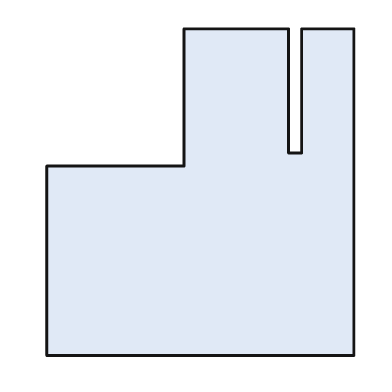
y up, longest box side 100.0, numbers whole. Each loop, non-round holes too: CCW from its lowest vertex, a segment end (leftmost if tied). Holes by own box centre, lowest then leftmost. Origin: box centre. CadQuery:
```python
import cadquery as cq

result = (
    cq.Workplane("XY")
    .moveTo(-47.0, -50.0)
    .lineTo(47.0, -50.0)
    .lineTo(47.0, 50.0)
    .lineTo(31.0, 50.0)
    .lineTo(31.0, 12.0)
    .lineTo(27.0, 12.0)
    .lineTo(27.0, 50.0)
    .lineTo(-5.0, 50.0)
    .lineTo(-5.0, 8.0)
    .lineTo(-47.0, 8.0)
    .close()
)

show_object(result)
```